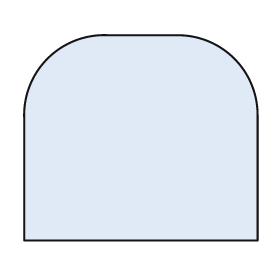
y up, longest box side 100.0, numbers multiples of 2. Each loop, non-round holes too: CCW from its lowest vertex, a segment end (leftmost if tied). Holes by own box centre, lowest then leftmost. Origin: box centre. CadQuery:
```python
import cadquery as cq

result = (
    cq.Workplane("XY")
    .moveTo(-50.0, -44.0)
    .lineTo(50.0, -44.0)
    .lineTo(50.0, 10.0)
    .threePointArc((40.0, 34.0), (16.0, 44.0))
    .lineTo(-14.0, 44.0)
    .threePointArc((-40.0, 34.0), (-50.0, 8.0))
    .close()
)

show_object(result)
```